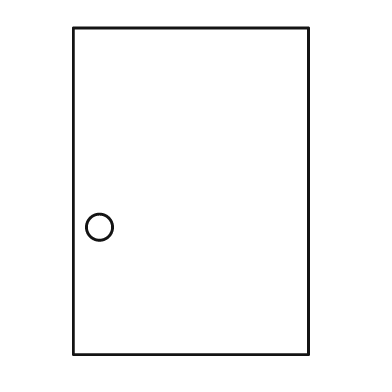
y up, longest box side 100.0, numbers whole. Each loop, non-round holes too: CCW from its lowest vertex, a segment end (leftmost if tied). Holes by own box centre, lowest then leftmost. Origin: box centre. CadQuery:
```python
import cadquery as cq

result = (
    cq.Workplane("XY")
    .moveTo(-36.0, -50.0)
    .lineTo(36.0, -50.0)
    .lineTo(36.0, 50.0)
    .lineTo(-36.0, 50.0)
    .close()
    .moveTo(-28.0, -11.0)
    .circle(4.0)
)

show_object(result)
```